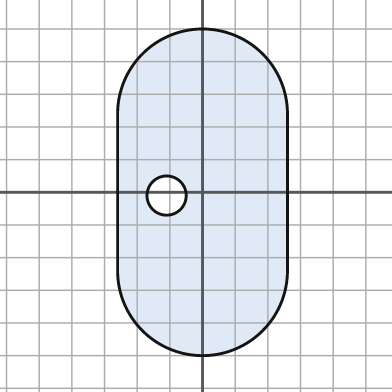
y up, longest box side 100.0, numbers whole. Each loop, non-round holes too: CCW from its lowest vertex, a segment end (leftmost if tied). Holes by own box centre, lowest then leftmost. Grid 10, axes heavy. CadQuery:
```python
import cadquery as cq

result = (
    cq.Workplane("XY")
    .moveTo(-26.0, -24.0)
    .threePointArc((0.0, -50.0), (26.0, -24.0))
    .lineTo(26.0, 24.0)
    .threePointArc((0.0, 50.0), (-26.0, 24.0))
    .close()
    .moveTo(-11.0, -1.0)
    .circle(6.0)
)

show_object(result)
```